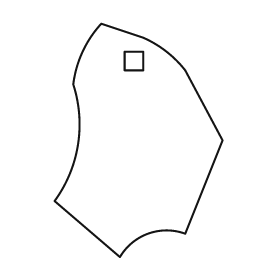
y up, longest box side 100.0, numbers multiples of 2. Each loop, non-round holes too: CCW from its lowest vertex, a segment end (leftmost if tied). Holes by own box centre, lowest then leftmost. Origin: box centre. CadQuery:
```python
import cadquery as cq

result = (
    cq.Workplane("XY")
    .moveTo(-8.0, -50.0)
    .threePointArc((4.0, -40.0), (20.0, -40.0))
    .lineTo(36.0, 0.0)
    .lineTo(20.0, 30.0)
    .threePointArc((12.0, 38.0), (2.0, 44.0))
    .lineTo(-16.0, 50.0)
    .threePointArc((-24.0, 38.0), (-28.0, 24.0))
    .threePointArc((-26.0, -2.0), (-36.0, -26.0))
    .close()
    .moveTo(-6.0, 30.0)
    .lineTo(2.0, 30.0)
    .lineTo(2.0, 38.0)
    .lineTo(-6.0, 38.0)
    .close()
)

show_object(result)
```